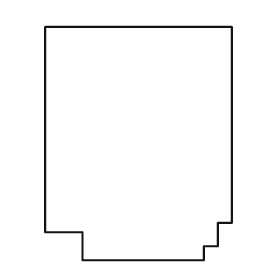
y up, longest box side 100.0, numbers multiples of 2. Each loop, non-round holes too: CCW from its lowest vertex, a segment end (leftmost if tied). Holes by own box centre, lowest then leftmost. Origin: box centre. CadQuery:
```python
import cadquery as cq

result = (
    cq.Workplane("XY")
    .moveTo(-24.0, -50.0)
    .lineTo(28.0, -50.0)
    .lineTo(28.0, -44.0)
    .lineTo(34.0, -44.0)
    .lineTo(34.0, -34.0)
    .lineTo(40.0, -34.0)
    .lineTo(40.0, 50.0)
    .lineTo(-40.0, 50.0)
    .lineTo(-40.0, -38.0)
    .lineTo(-24.0, -38.0)
    .close()
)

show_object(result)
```